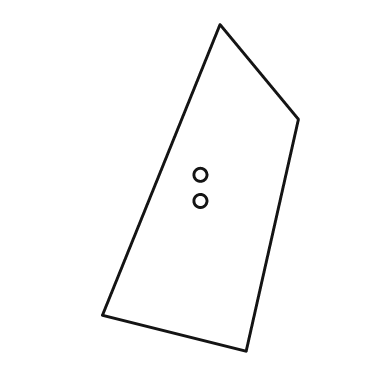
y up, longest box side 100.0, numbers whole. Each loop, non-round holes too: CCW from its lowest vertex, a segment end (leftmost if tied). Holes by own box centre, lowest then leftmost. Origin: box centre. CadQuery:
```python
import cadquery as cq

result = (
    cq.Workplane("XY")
    .moveTo(14.0, -50.0)
    .lineTo(30.0, 21.0)
    .lineTo(6.0, 50.0)
    .lineTo(-30.0, -39.0)
    .close()
    .moveTo(0.0, -4.0)
    .circle(2.0)
    .moveTo(0.0, 4.0)
    .circle(2.0)
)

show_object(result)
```